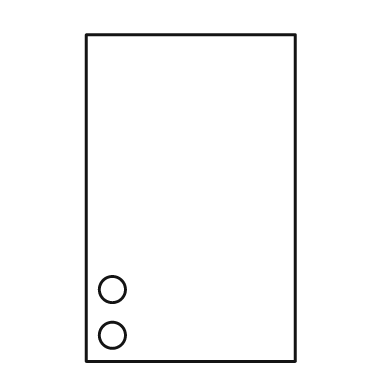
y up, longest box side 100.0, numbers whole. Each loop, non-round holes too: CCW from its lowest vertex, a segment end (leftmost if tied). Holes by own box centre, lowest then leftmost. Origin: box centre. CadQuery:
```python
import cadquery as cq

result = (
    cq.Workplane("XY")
    .moveTo(-32.0, -50.0)
    .lineTo(32.0, -50.0)
    .lineTo(32.0, 50.0)
    .lineTo(-32.0, 50.0)
    .close()
    .moveTo(-24.0, -42.0)
    .circle(4.0)
    .moveTo(-24.0, -28.0)
    .circle(4.0)
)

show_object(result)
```